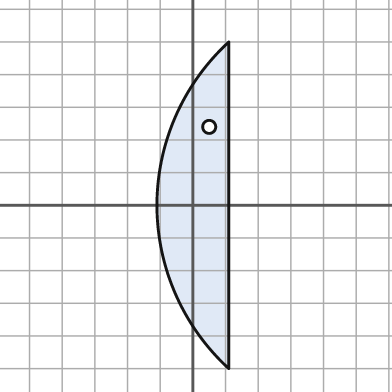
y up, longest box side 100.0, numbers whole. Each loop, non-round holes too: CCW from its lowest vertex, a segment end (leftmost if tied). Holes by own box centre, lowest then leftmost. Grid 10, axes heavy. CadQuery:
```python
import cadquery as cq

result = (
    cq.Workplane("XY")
    .moveTo(11.0, -50.0)
    .lineTo(11.0, 50.0)
    .threePointArc((-11.0, 0.0), (11.0, -50.0))
    .close()
    .moveTo(5.0, 24.0)
    .circle(2.0)
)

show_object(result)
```